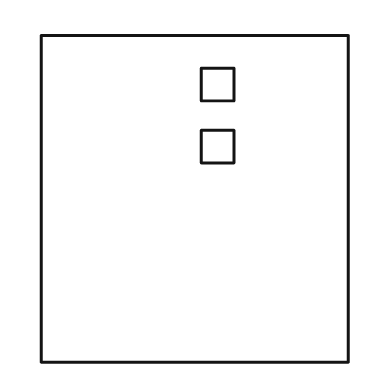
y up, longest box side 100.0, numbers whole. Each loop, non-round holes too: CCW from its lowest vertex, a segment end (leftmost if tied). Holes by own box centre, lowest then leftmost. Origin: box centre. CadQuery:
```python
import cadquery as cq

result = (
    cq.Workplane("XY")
    .moveTo(-47.0, -50.0)
    .lineTo(47.0, -50.0)
    .lineTo(47.0, 50.0)
    .lineTo(-47.0, 50.0)
    .close()
    .moveTo(2.0, 11.0)
    .lineTo(12.0, 11.0)
    .lineTo(12.0, 21.0)
    .lineTo(2.0, 21.0)
    .close()
    .moveTo(2.0, 30.0)
    .lineTo(12.0, 30.0)
    .lineTo(12.0, 40.0)
    .lineTo(2.0, 40.0)
    .close()
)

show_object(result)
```